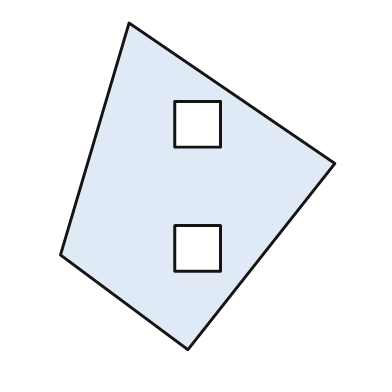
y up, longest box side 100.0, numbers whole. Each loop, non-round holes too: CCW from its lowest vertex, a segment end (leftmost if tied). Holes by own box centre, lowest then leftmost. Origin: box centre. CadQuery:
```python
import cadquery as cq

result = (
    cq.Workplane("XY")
    .moveTo(-3.0, -50.0)
    .lineTo(42.0, 7.0)
    .lineTo(-21.0, 50.0)
    .lineTo(-42.0, -21.0)
    .close()
    .moveTo(-7.0, -26.0)
    .lineTo(7.0, -26.0)
    .lineTo(7.0, -12.0)
    .lineTo(-7.0, -12.0)
    .close()
    .moveTo(-7.0, 12.0)
    .lineTo(7.0, 12.0)
    .lineTo(7.0, 26.0)
    .lineTo(-7.0, 26.0)
    .close()
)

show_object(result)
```